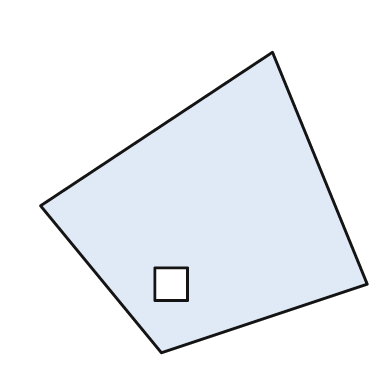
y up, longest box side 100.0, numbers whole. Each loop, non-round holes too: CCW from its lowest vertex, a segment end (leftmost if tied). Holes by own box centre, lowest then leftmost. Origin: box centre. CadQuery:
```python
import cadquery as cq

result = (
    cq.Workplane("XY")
    .moveTo(-13.0, -46.0)
    .lineTo(50.0, -25.0)
    .lineTo(21.0, 46.0)
    .lineTo(-50.0, -1.0)
    .close()
    .moveTo(-15.0, -30.0)
    .lineTo(-5.0, -30.0)
    .lineTo(-5.0, -20.0)
    .lineTo(-15.0, -20.0)
    .close()
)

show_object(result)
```